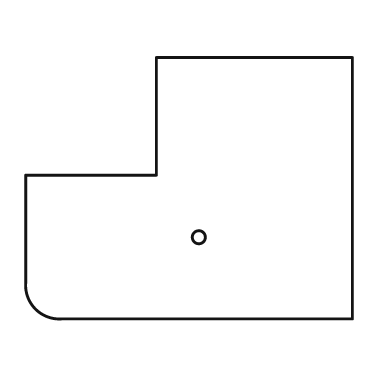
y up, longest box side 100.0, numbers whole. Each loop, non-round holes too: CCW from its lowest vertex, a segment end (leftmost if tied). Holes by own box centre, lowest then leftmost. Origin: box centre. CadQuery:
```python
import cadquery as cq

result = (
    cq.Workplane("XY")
    .moveTo(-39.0, -40.0)
    .lineTo(50.0, -40.0)
    .lineTo(50.0, 40.0)
    .lineTo(-10.0, 40.0)
    .lineTo(-10.0, 4.0)
    .lineTo(-50.0, 4.0)
    .lineTo(-50.0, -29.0)
    .threePointArc((-47.0, -37.0), (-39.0, -40.0))
    .close()
    .moveTo(3.0, -15.0)
    .circle(2.0)
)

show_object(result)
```